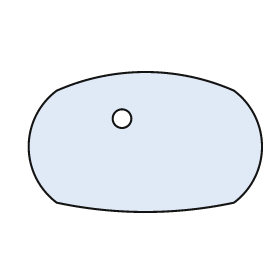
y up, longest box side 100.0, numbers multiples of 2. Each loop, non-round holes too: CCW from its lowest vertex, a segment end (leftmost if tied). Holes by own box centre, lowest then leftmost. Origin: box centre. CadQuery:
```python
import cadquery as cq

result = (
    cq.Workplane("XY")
    .moveTo(-38.0, -26.0)
    .threePointArc((0.0, -30.0), (38.0, -26.0))
    .threePointArc((50.0, -2.0), (38.0, 22.0))
    .threePointArc((0.0, 30.0), (-38.0, 22.0))
    .threePointArc((-50.0, -2.0), (-38.0, -26.0))
    .close()
    .moveTo(-10.0, 10.0)
    .circle(4.0)
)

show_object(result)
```